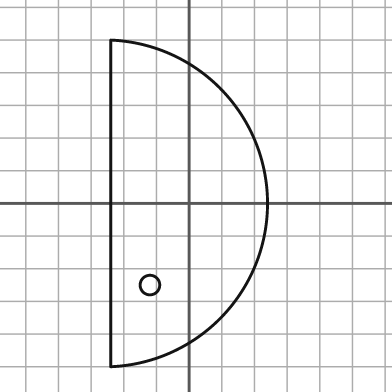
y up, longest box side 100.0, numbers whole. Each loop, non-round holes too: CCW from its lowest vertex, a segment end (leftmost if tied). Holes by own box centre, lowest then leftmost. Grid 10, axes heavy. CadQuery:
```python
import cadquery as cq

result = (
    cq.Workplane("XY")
    .moveTo(-24.0, -50.0)
    .threePointArc((24.0, 0.0), (-24.0, 50.0))
    .close()
    .moveTo(-12.0, -25.0)
    .circle(3.0)
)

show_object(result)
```